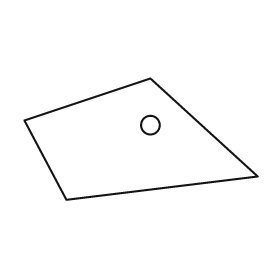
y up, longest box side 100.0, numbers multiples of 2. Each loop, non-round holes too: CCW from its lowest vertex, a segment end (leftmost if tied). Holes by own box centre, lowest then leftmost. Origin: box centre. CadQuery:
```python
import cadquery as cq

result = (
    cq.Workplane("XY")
    .moveTo(-32.0, -26.0)
    .lineTo(50.0, -16.0)
    .lineTo(4.0, 26.0)
    .lineTo(-50.0, 8.0)
    .close()
    .moveTo(4.0, 6.0)
    .circle(4.0)
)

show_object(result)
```